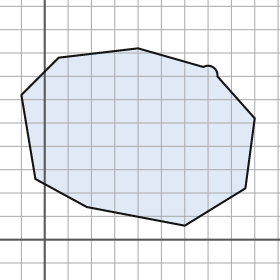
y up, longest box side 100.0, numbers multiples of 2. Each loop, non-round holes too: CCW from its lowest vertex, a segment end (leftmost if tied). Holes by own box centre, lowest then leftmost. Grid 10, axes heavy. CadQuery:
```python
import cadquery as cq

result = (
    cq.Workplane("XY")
    .moveTo(60.0, 6.0)
    .lineTo(86.0, 22.0)
    .lineTo(90.0, 52.0)
    .lineTo(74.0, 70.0)
    .threePointArc((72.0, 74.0), (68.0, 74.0))
    .lineTo(40.0, 82.0)
    .lineTo(6.0, 78.0)
    .lineTo(-10.0, 62.0)
    .lineTo(-4.0, 26.0)
    .lineTo(18.0, 14.0)
    .close()
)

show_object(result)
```